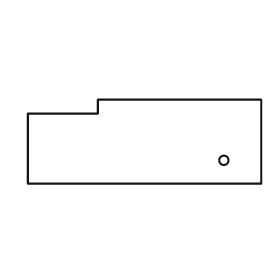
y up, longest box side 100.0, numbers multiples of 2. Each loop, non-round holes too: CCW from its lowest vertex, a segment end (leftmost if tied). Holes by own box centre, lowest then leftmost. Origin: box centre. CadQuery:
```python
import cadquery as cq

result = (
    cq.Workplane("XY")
    .moveTo(-50.0, -18.0)
    .lineTo(50.0, -18.0)
    .lineTo(50.0, 18.0)
    .lineTo(-20.0, 18.0)
    .lineTo(-20.0, 12.0)
    .lineTo(-50.0, 12.0)
    .close()
    .moveTo(34.0, -8.0)
    .circle(2.0)
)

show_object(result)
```